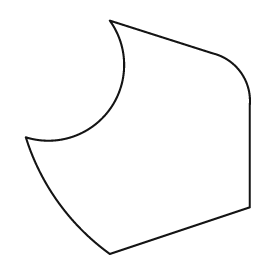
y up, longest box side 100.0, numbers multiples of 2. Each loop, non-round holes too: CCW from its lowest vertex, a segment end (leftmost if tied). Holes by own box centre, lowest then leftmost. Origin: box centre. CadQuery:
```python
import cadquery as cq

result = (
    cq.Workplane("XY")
    .moveTo(-12.0, -50.0)
    .lineTo(48.0, -30.0)
    .lineTo(48.0, 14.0)
    .threePointArc((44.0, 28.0), (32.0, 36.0))
    .lineTo(-12.0, 50.0)
    .threePointArc((-12.0, 12.0), (-48.0, 0.0))
    .threePointArc((-34.0, -28.0), (-12.0, -50.0))
    .close()
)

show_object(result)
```